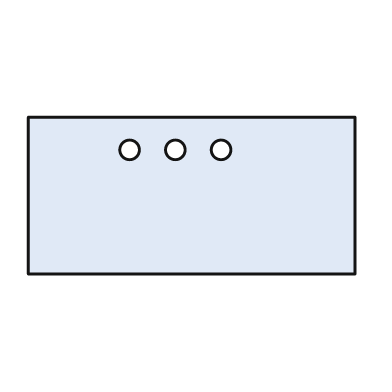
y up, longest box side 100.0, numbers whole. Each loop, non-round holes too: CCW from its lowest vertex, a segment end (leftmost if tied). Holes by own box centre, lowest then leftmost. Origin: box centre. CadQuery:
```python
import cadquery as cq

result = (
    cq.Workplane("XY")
    .moveTo(-50.0, -24.0)
    .lineTo(50.0, -24.0)
    .lineTo(50.0, 24.0)
    .lineTo(-50.0, 24.0)
    .close()
    .moveTo(-19.0, 14.0)
    .circle(3.0)
    .moveTo(-5.0, 14.0)
    .circle(3.0)
    .moveTo(9.0, 14.0)
    .circle(3.0)
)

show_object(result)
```